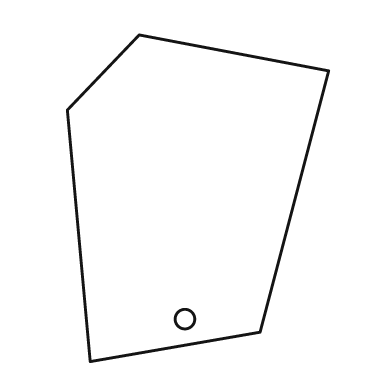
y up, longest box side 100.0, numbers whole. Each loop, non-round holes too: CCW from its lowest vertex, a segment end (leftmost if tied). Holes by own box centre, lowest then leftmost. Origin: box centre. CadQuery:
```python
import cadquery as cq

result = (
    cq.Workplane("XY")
    .moveTo(-33.0, -50.0)
    .lineTo(19.0, -41.0)
    .lineTo(40.0, 39.0)
    .lineTo(-18.0, 50.0)
    .lineTo(-40.0, 27.0)
    .close()
    .moveTo(-4.0, -37.0)
    .circle(3.0)
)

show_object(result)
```